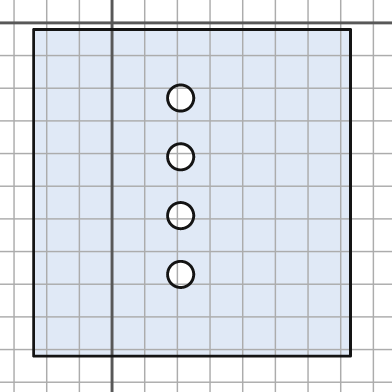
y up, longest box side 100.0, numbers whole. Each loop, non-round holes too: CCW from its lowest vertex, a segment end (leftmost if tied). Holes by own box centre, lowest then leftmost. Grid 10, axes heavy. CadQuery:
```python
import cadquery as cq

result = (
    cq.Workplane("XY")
    .moveTo(-24.0, -102.0)
    .lineTo(73.0, -102.0)
    .lineTo(73.0, -2.0)
    .lineTo(-24.0, -2.0)
    .close()
    .moveTo(21.0, -77.0)
    .circle(4.0)
    .moveTo(21.0, -59.0)
    .circle(4.0)
    .moveTo(21.0, -41.0)
    .circle(4.0)
    .moveTo(21.0, -23.0)
    .circle(4.0)
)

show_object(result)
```